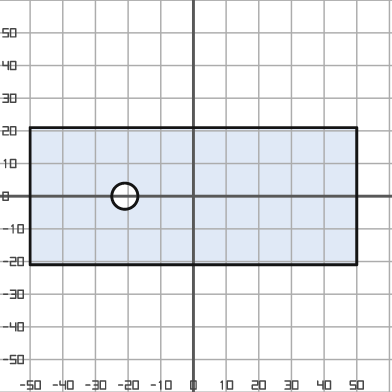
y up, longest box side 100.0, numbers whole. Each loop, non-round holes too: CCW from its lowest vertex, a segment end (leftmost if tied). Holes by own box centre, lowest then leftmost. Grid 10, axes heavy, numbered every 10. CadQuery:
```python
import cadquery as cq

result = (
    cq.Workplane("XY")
    .moveTo(-50.0, -21.0)
    .lineTo(50.0, -21.0)
    .lineTo(50.0, 21.0)
    .lineTo(-50.0, 21.0)
    .close()
    .moveTo(-21.0, 0.0)
    .circle(4.0)
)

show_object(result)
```